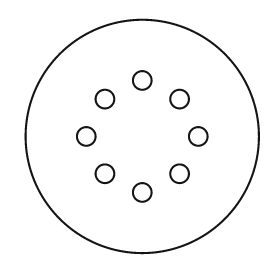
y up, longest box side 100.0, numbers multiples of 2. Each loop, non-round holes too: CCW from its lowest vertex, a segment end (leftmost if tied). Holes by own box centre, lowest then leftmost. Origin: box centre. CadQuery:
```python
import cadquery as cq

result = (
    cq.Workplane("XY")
    .moveTo(0.0, 0.0)
    .circle(50.0)
    .moveTo(0.0, -24.0)
    .circle(4.0)
    .moveTo(-16.0, -16.0)
    .circle(4.0)
    .moveTo(16.0, -16.0)
    .circle(4.0)
    .moveTo(-24.0, 0.0)
    .circle(4.0)
    .moveTo(24.0, 0.0)
    .circle(4.0)
    .moveTo(-16.0, 16.0)
    .circle(4.0)
    .moveTo(16.0, 16.0)
    .circle(4.0)
    .moveTo(0.0, 24.0)
    .circle(4.0)
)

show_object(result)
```